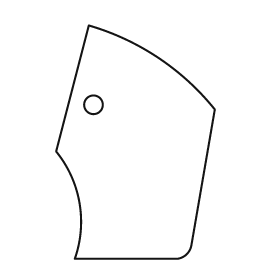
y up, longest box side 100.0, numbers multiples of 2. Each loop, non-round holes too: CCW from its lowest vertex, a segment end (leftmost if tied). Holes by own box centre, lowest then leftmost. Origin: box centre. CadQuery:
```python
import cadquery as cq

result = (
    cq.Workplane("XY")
    .moveTo(-26.0, -50.0)
    .lineTo(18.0, -50.0)
    .threePointArc((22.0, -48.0), (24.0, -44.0))
    .lineTo(34.0, 14.0)
    .threePointArc((10.0, 36.0), (-20.0, 50.0))
    .lineTo(-34.0, -4.0)
    .threePointArc((-24.0, -26.0), (-26.0, -50.0))
    .close()
    .moveTo(-18.0, 16.0)
    .circle(4.0)
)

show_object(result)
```